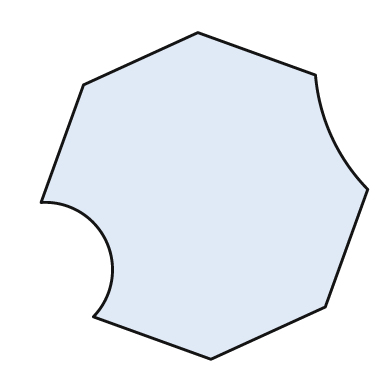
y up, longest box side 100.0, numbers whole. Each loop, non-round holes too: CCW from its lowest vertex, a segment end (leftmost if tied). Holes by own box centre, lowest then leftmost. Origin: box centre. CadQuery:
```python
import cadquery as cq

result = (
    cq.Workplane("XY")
    .moveTo(2.0, -50.0)
    .lineTo(37.0, -34.0)
    .lineTo(50.0, 2.0)
    .threePointArc((39.0, 18.0), (34.0, 37.0))
    .lineTo(-2.0, 50.0)
    .lineTo(-37.0, 34.0)
    .lineTo(-50.0, -2.0)
    .threePointArc((-30.0, -14.0), (-34.0, -37.0))
    .close()
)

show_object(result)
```